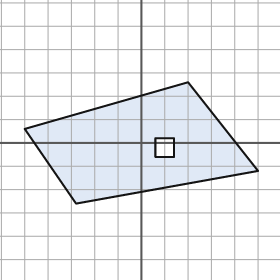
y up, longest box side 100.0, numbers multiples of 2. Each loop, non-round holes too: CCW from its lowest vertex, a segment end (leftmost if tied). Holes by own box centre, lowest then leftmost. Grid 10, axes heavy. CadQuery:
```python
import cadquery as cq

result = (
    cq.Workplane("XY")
    .moveTo(-28.0, -26.0)
    .lineTo(50.0, -12.0)
    .lineTo(20.0, 26.0)
    .lineTo(-50.0, 6.0)
    .close()
    .moveTo(6.0, -6.0)
    .lineTo(14.0, -6.0)
    .lineTo(14.0, 2.0)
    .lineTo(6.0, 2.0)
    .close()
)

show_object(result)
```